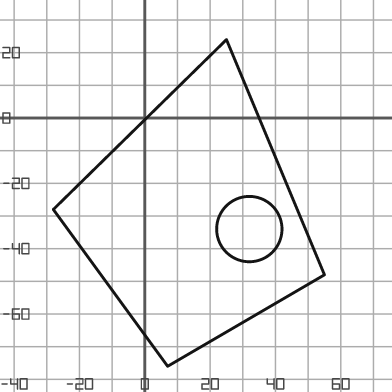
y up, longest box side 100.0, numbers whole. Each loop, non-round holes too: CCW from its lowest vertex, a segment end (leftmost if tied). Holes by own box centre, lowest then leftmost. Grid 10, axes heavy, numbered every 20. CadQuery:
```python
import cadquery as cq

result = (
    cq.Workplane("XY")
    .moveTo(7.0, -76.0)
    .lineTo(55.0, -48.0)
    .lineTo(25.0, 24.0)
    .lineTo(-28.0, -28.0)
    .close()
    .moveTo(32.0, -34.0)
    .circle(10.0)
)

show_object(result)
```